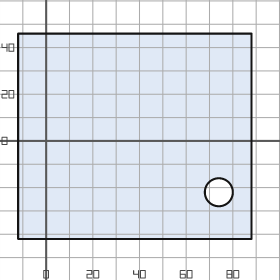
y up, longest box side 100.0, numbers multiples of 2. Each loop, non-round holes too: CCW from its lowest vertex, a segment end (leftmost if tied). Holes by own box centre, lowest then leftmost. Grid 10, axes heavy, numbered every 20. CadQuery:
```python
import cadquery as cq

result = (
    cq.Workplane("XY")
    .moveTo(-12.0, -42.0)
    .lineTo(88.0, -42.0)
    .lineTo(88.0, 46.0)
    .lineTo(-12.0, 46.0)
    .close()
    .moveTo(74.0, -22.0)
    .circle(6.0)
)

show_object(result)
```